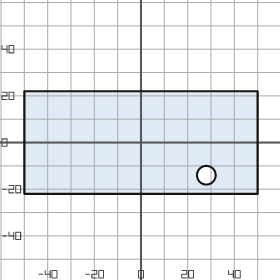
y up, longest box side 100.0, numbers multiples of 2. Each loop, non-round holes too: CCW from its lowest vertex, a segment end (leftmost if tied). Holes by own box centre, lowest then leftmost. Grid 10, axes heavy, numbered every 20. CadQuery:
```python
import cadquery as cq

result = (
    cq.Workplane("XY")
    .moveTo(-50.0, -22.0)
    .lineTo(50.0, -22.0)
    .lineTo(50.0, 22.0)
    .lineTo(-50.0, 22.0)
    .close()
    .moveTo(28.0, -14.0)
    .circle(4.0)
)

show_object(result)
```